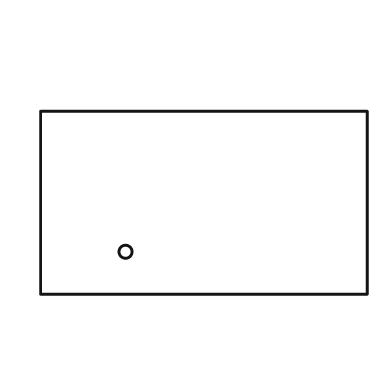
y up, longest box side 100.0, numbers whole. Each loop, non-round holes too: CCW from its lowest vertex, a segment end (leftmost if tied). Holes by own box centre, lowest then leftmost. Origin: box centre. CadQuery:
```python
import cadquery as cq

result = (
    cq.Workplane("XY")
    .moveTo(-50.0, -28.0)
    .lineTo(50.0, -28.0)
    .lineTo(50.0, 28.0)
    .lineTo(-50.0, 28.0)
    .close()
    .moveTo(-24.0, -15.0)
    .circle(2.0)
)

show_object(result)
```